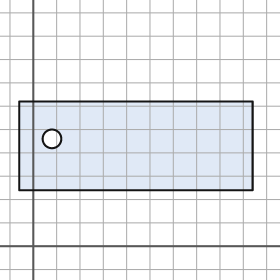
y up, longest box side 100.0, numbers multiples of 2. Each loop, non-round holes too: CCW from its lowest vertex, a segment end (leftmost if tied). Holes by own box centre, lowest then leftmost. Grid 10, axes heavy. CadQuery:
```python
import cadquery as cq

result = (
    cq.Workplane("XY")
    .moveTo(-6.0, 24.0)
    .lineTo(94.0, 24.0)
    .lineTo(94.0, 62.0)
    .lineTo(-6.0, 62.0)
    .close()
    .moveTo(8.0, 46.0)
    .circle(4.0)
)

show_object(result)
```